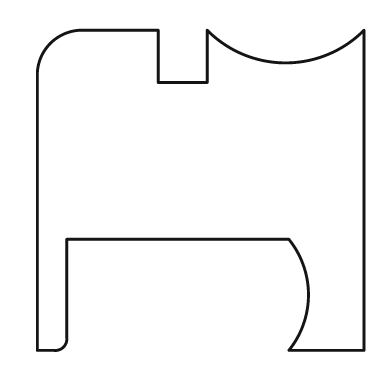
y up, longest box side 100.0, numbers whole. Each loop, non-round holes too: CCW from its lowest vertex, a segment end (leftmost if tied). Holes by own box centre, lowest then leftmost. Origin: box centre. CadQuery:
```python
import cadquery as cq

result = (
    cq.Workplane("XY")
    .moveTo(-50.0, -49.0)
    .lineTo(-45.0, -49.0)
    .threePointArc((-42.0, -48.0), (-41.0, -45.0))
    .lineTo(-41.0, -15.0)
    .lineTo(27.0, -15.0)
    .threePointArc((33.0, -32.0), (27.0, -49.0))
    .lineTo(50.0, -49.0)
    .lineTo(50.0, 49.0)
    .threePointArc((26.0, 39.0), (2.0, 49.0))
    .lineTo(2.0, 33.0)
    .lineTo(-13.0, 33.0)
    .lineTo(-13.0, 49.0)
    .lineTo(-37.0, 49.0)
    .threePointArc((-46.0, 45.0), (-50.0, 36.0))
    .close()
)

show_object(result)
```